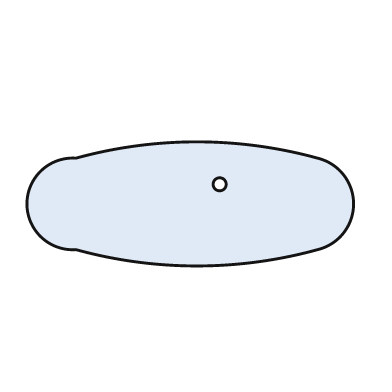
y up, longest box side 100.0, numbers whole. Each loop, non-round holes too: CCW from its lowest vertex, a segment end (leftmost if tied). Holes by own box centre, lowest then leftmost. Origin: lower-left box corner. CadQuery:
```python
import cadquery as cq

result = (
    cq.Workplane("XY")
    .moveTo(15.0, 5.0)
    .threePointArc((52.0, 0.0), (89.0, 5.0))
    .threePointArc((100.0, 19.0), (89.0, 33.0))
    .threePointArc((52.0, 38.0), (15.0, 33.0))
    .threePointArc((0.0, 19.0), (15.0, 5.0))
    .close()
    .moveTo(59.0, 25.0)
    .circle(2.0)
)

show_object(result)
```